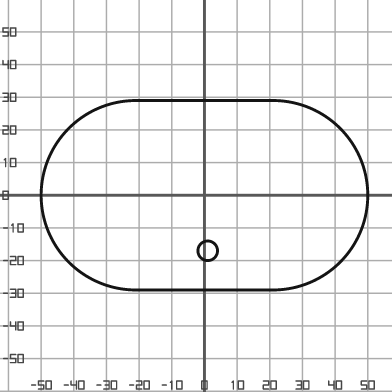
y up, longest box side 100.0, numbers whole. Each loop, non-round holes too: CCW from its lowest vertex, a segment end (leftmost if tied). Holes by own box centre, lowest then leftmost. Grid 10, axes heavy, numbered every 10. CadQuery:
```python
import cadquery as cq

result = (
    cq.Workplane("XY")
    .moveTo(-21.0, -29.0)
    .lineTo(21.0, -29.0)
    .threePointArc((50.0, 0.0), (21.0, 29.0))
    .lineTo(-21.0, 29.0)
    .threePointArc((-50.0, 0.0), (-21.0, -29.0))
    .close()
    .moveTo(1.0, -17.0)
    .circle(3.0)
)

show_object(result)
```